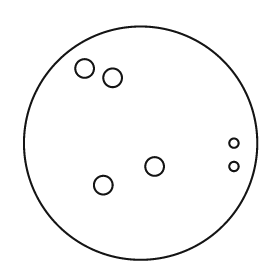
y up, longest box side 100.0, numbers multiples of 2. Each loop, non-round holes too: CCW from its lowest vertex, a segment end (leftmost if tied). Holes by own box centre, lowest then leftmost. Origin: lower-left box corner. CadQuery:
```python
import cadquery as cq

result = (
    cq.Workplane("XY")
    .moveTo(50.0, 50.0)
    .circle(50.0)
    .moveTo(34.0, 32.0)
    .circle(4.0)
    .moveTo(56.0, 40.0)
    .circle(4.0)
    .moveTo(90.0, 40.0)
    .circle(2.0)
    .moveTo(90.0, 50.0)
    .circle(2.0)
    .moveTo(38.0, 78.0)
    .circle(4.0)
    .moveTo(26.0, 82.0)
    .circle(4.0)
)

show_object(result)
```